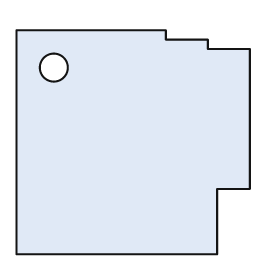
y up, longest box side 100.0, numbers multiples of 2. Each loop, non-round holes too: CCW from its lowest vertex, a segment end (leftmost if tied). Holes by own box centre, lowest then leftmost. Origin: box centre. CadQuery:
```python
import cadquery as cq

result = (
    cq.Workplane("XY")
    .moveTo(-50.0, -48.0)
    .lineTo(36.0, -48.0)
    .lineTo(36.0, -20.0)
    .lineTo(50.0, -20.0)
    .lineTo(50.0, 40.0)
    .lineTo(32.0, 40.0)
    .lineTo(32.0, 44.0)
    .lineTo(14.0, 44.0)
    .lineTo(14.0, 48.0)
    .lineTo(-50.0, 48.0)
    .close()
    .moveTo(-34.0, 32.0)
    .circle(6.0)
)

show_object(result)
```